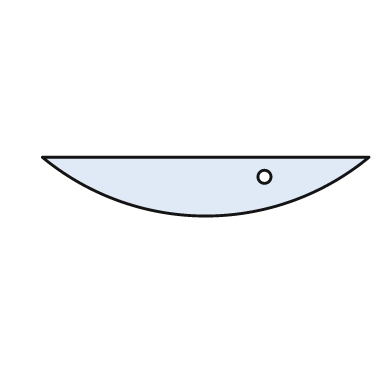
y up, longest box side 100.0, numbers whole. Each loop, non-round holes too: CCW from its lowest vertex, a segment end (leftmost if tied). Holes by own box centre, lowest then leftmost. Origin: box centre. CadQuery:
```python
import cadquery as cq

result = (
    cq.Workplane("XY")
    .moveTo(-50.0, 9.0)
    .threePointArc((0.0, -9.0), (50.0, 9.0))
    .close()
    .moveTo(18.0, 3.0)
    .circle(2.0)
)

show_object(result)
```